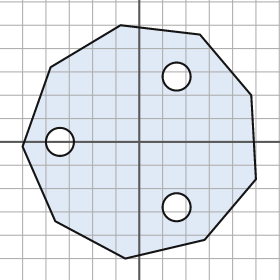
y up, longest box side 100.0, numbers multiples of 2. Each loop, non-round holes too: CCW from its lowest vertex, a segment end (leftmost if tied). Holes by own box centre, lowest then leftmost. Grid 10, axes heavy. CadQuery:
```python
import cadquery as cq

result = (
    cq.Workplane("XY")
    .moveTo(-6.0, -50.0)
    .lineTo(28.0, -42.0)
    .lineTo(50.0, -16.0)
    .lineTo(48.0, 20.0)
    .lineTo(26.0, 46.0)
    .lineTo(-8.0, 50.0)
    .lineTo(-38.0, 32.0)
    .lineTo(-50.0, -2.0)
    .lineTo(-36.0, -34.0)
    .close()
    .moveTo(16.0, -28.0)
    .circle(6.0)
    .moveTo(-34.0, 0.0)
    .circle(6.0)
    .moveTo(16.0, 28.0)
    .circle(6.0)
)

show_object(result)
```